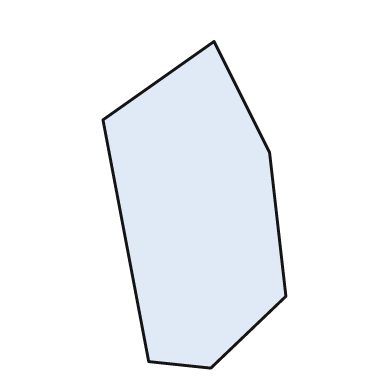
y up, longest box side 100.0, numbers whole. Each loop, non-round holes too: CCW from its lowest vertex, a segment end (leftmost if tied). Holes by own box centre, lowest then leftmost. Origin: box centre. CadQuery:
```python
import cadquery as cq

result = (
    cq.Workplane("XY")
    .moveTo(5.0, -50.0)
    .lineTo(28.0, -28.0)
    .lineTo(23.0, 16.0)
    .lineTo(6.0, 50.0)
    .lineTo(-28.0, 26.0)
    .lineTo(-14.0, -48.0)
    .close()
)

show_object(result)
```